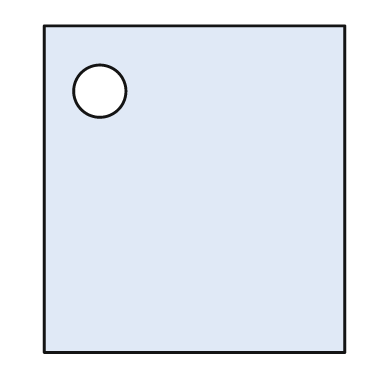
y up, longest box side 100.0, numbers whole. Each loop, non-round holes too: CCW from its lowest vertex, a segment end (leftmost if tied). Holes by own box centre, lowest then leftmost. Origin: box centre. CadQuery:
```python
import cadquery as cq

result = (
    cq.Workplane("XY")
    .moveTo(-46.0, -50.0)
    .lineTo(46.0, -50.0)
    .lineTo(46.0, 50.0)
    .lineTo(-46.0, 50.0)
    .close()
    .moveTo(-29.0, 30.0)
    .circle(8.0)
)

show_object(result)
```